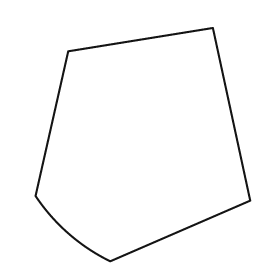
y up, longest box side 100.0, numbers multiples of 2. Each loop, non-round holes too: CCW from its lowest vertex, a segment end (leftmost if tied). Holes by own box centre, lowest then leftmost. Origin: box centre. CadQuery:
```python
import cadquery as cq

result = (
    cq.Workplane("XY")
    .moveTo(-14.0, -50.0)
    .lineTo(46.0, -24.0)
    .lineTo(30.0, 50.0)
    .lineTo(-32.0, 40.0)
    .lineTo(-46.0, -22.0)
    .threePointArc((-32.0, -38.0), (-14.0, -50.0))
    .close()
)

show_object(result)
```